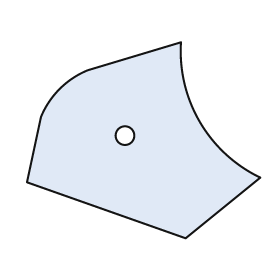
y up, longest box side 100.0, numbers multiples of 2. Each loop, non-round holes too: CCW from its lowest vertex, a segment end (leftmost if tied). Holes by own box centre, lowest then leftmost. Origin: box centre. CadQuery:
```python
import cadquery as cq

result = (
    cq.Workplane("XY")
    .moveTo(18.0, -42.0)
    .lineTo(50.0, -16.0)
    .threePointArc((24.0, 8.0), (16.0, 42.0))
    .lineTo(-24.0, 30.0)
    .threePointArc((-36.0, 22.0), (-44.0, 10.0))
    .lineTo(-50.0, -18.0)
    .close()
    .moveTo(-8.0, 2.0)
    .circle(4.0)
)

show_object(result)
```